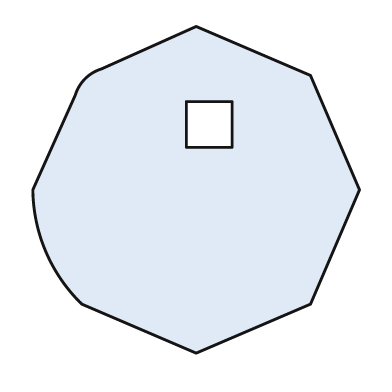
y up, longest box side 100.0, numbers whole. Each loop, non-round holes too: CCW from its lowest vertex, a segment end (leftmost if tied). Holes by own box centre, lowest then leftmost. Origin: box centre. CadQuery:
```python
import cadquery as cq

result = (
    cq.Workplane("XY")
    .moveTo(0.0, -50.0)
    .lineTo(35.0, -35.0)
    .lineTo(50.0, 0.0)
    .lineTo(35.0, 35.0)
    .lineTo(0.0, 50.0)
    .lineTo(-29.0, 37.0)
    .threePointArc((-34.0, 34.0), (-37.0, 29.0))
    .lineTo(-50.0, 0.0)
    .threePointArc((-46.0, -19.0), (-35.0, -35.0))
    .close()
    .moveTo(-3.0, 13.0)
    .lineTo(11.0, 13.0)
    .lineTo(11.0, 27.0)
    .lineTo(-3.0, 27.0)
    .close()
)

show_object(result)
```